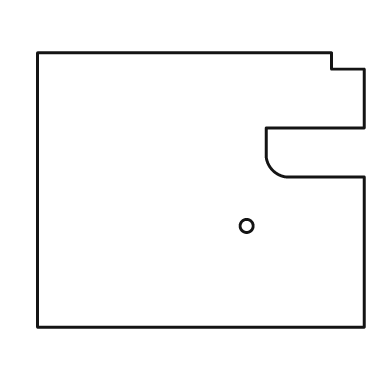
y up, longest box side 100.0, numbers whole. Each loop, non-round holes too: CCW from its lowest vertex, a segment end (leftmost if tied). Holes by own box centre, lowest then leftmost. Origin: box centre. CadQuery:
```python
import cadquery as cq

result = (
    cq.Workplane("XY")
    .moveTo(-50.0, -42.0)
    .lineTo(50.0, -42.0)
    .lineTo(50.0, 4.0)
    .lineTo(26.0, 4.0)
    .threePointArc((22.0, 6.0), (20.0, 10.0))
    .lineTo(20.0, 19.0)
    .lineTo(50.0, 19.0)
    .lineTo(50.0, 37.0)
    .lineTo(40.0, 37.0)
    .lineTo(40.0, 42.0)
    .lineTo(-50.0, 42.0)
    .close()
    .moveTo(14.0, -11.0)
    .circle(2.0)
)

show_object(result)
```